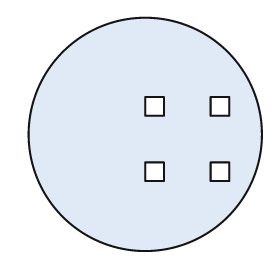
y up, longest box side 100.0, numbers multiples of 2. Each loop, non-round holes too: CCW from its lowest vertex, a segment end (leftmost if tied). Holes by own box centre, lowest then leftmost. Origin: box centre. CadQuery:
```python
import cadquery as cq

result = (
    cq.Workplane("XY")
    .moveTo(0.0, 0.0)
    .circle(50.0)
    .moveTo(0.0, -20.0)
    .lineTo(8.0, -20.0)
    .lineTo(8.0, -12.0)
    .lineTo(0.0, -12.0)
    .close()
    .moveTo(28.0, -20.0)
    .lineTo(36.0, -20.0)
    .lineTo(36.0, -12.0)
    .lineTo(28.0, -12.0)
    .close()
    .moveTo(0.0, 8.0)
    .lineTo(8.0, 8.0)
    .lineTo(8.0, 16.0)
    .lineTo(0.0, 16.0)
    .close()
    .moveTo(28.0, 8.0)
    .lineTo(36.0, 8.0)
    .lineTo(36.0, 16.0)
    .lineTo(28.0, 16.0)
    .close()
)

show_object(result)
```